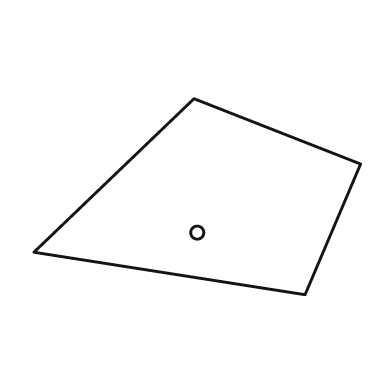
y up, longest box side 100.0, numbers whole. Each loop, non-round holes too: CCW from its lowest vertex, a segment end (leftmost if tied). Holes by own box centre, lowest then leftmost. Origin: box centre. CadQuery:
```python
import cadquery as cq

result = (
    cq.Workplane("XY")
    .moveTo(33.0, -30.0)
    .lineTo(50.0, 10.0)
    .lineTo(-1.0, 30.0)
    .lineTo(-50.0, -17.0)
    .close()
    .moveTo(0.0, -11.0)
    .circle(2.0)
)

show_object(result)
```